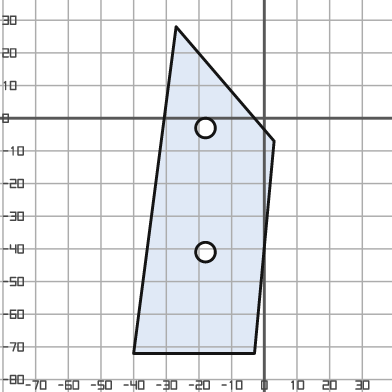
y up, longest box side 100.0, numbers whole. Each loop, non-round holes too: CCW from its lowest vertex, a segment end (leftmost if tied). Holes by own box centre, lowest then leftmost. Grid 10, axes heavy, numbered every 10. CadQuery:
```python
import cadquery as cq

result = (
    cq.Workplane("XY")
    .moveTo(-40.0, -72.0)
    .lineTo(-3.0, -72.0)
    .lineTo(3.0, -7.0)
    .lineTo(-27.0, 28.0)
    .close()
    .moveTo(-18.0, -41.0)
    .circle(3.0)
    .moveTo(-18.0, -3.0)
    .circle(3.0)
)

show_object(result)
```